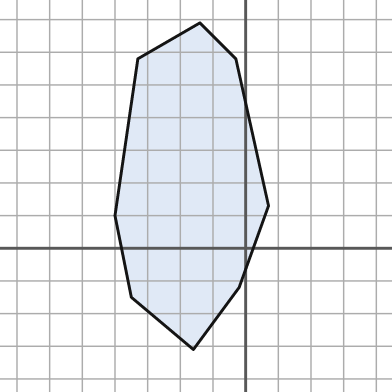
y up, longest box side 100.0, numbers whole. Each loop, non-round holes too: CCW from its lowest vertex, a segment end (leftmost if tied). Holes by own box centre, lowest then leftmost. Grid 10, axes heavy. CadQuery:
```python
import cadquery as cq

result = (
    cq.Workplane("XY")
    .moveTo(-16.0, -31.0)
    .lineTo(-2.0, -12.0)
    .lineTo(7.0, 13.0)
    .lineTo(-3.0, 58.0)
    .lineTo(-14.0, 69.0)
    .lineTo(-33.0, 58.0)
    .lineTo(-40.0, 10.0)
    .lineTo(-35.0, -15.0)
    .close()
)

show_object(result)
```